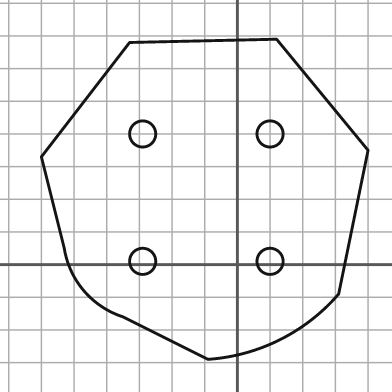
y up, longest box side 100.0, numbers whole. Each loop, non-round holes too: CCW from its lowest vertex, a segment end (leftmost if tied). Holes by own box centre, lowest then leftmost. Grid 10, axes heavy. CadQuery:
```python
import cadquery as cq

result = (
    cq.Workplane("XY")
    .moveTo(-9.0, -29.0)
    .threePointArc((13.0, -23.0), (31.0, -9.0))
    .lineTo(40.0, 35.0)
    .lineTo(12.0, 69.0)
    .lineTo(-33.0, 68.0)
    .lineTo(-60.0, 33.0)
    .lineTo(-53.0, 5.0)
    .threePointArc((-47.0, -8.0), (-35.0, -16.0))
    .close()
    .moveTo(-29.0, 1.0)
    .circle(4.0)
    .moveTo(10.0, 1.0)
    .circle(4.0)
    .moveTo(-29.0, 40.0)
    .circle(4.0)
    .moveTo(10.0, 40.0)
    .circle(4.0)
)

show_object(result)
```